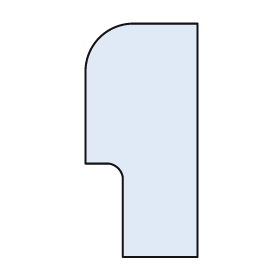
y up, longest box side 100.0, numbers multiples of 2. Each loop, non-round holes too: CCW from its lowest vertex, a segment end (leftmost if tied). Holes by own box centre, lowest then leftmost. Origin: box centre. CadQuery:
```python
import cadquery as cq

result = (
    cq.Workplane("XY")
    .moveTo(-8.0, -50.0)
    .lineTo(24.0, -50.0)
    .lineTo(24.0, 50.0)
    .lineTo(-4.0, 50.0)
    .threePointArc((-18.0, 44.0), (-24.0, 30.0))
    .lineTo(-24.0, -10.0)
    .lineTo(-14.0, -10.0)
    .threePointArc((-10.0, -12.0), (-8.0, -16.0))
    .close()
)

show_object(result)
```